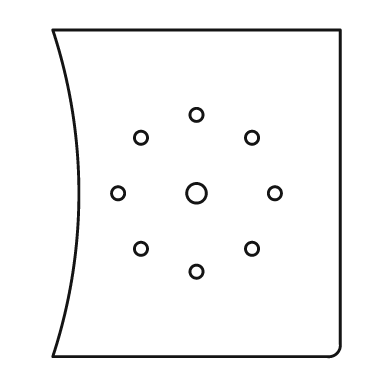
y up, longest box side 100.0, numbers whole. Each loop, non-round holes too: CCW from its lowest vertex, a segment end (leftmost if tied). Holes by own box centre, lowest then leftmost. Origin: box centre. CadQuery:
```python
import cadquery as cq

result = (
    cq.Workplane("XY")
    .moveTo(-44.0, -50.0)
    .lineTo(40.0, -50.0)
    .threePointArc((43.0, -49.0), (44.0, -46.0))
    .lineTo(44.0, 50.0)
    .lineTo(-44.0, 50.0)
    .threePointArc((-36.0, 0.0), (-44.0, -50.0))
    .close()
    .moveTo(0.0, -24.0)
    .circle(2.0)
    .moveTo(-17.0, -17.0)
    .circle(2.0)
    .moveTo(17.0, -17.0)
    .circle(2.0)
    .moveTo(-24.0, 0.0)
    .circle(2.0)
    .moveTo(0.0, 0.0)
    .circle(3.0)
    .moveTo(24.0, 0.0)
    .circle(2.0)
    .moveTo(-17.0, 17.0)
    .circle(2.0)
    .moveTo(17.0, 17.0)
    .circle(2.0)
    .moveTo(0.0, 24.0)
    .circle(2.0)
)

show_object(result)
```